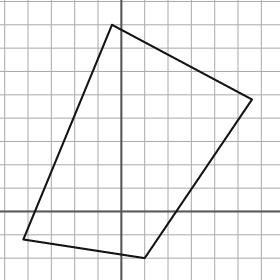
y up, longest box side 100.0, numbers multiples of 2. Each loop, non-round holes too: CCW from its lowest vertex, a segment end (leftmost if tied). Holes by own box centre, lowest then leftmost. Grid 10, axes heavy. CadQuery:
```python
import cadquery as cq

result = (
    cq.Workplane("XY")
    .moveTo(10.0, -20.0)
    .lineTo(56.0, 48.0)
    .lineTo(-4.0, 80.0)
    .lineTo(-42.0, -12.0)
    .close()
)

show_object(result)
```